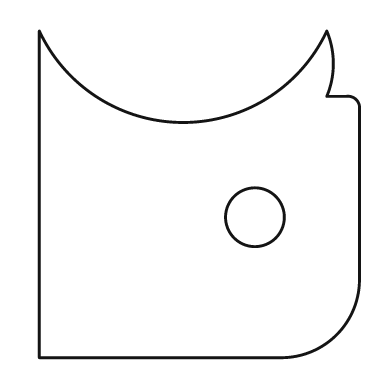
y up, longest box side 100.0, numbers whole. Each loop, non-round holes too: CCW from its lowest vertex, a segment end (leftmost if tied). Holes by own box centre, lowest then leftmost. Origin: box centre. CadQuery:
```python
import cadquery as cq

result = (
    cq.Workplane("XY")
    .moveTo(-49.0, -50.0)
    .lineTo(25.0, -50.0)
    .threePointArc((42.0, -43.0), (49.0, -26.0))
    .lineTo(49.0, 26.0)
    .threePointArc((48.0, 29.0), (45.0, 30.0))
    .lineTo(39.0, 30.0)
    .threePointArc((41.0, 40.0), (39.0, 50.0))
    .threePointArc((-5.0, 22.0), (-49.0, 50.0))
    .close()
    .moveTo(17.0, -7.0)
    .circle(9.0)
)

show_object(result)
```